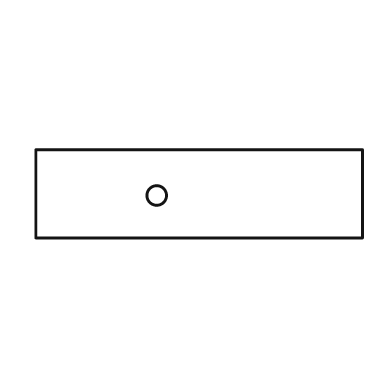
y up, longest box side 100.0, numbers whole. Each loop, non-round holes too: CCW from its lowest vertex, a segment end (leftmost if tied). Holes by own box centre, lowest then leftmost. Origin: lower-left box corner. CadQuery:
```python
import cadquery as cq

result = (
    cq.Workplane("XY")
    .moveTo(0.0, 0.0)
    .lineTo(100.0, 0.0)
    .lineTo(100.0, 27.0)
    .lineTo(0.0, 27.0)
    .close()
    .moveTo(37.0, 13.0)
    .circle(3.0)
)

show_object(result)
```